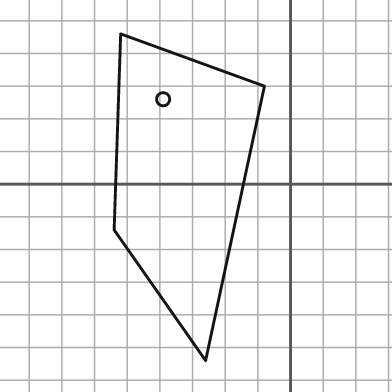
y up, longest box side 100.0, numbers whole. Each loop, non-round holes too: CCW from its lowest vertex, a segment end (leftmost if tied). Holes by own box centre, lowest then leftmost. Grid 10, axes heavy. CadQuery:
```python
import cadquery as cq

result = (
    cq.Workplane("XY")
    .moveTo(-26.0, -54.0)
    .lineTo(-8.0, 30.0)
    .lineTo(-52.0, 46.0)
    .lineTo(-54.0, -14.0)
    .close()
    .moveTo(-39.0, 26.0)
    .circle(2.0)
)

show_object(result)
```